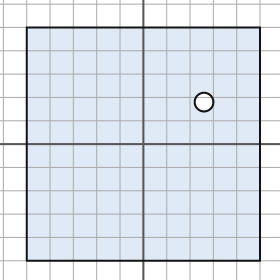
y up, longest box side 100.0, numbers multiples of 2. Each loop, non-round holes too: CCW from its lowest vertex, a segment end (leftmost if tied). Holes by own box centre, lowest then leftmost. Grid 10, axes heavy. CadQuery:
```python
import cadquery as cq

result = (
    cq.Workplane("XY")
    .moveTo(-50.0, -50.0)
    .lineTo(50.0, -50.0)
    .lineTo(50.0, 50.0)
    .lineTo(-50.0, 50.0)
    .close()
    .moveTo(26.0, 18.0)
    .circle(4.0)
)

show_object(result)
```